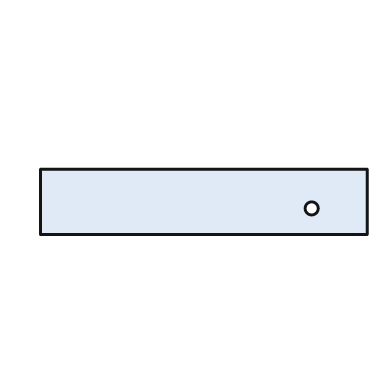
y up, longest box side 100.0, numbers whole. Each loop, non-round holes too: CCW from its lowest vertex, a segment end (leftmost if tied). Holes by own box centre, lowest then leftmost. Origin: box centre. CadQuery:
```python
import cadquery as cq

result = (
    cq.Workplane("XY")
    .moveTo(-50.0, -10.0)
    .lineTo(50.0, -10.0)
    .lineTo(50.0, 10.0)
    .lineTo(-50.0, 10.0)
    .close()
    .moveTo(33.0, -2.0)
    .circle(2.0)
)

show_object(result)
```